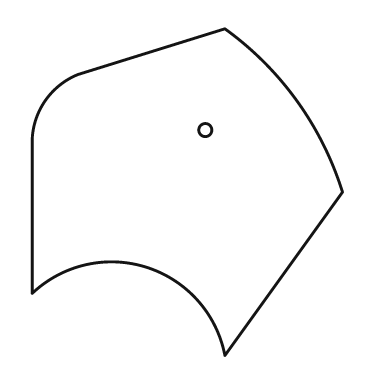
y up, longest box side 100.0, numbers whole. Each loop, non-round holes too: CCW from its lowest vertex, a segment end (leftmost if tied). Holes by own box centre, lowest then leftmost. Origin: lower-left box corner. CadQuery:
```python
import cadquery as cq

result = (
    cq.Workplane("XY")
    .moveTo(59.0, 0.0)
    .lineTo(95.0, 50.0)
    .threePointArc((81.0, 78.0), (59.0, 100.0))
    .lineTo(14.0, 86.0)
    .threePointArc((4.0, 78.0), (0.0, 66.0))
    .lineTo(0.0, 19.0)
    .threePointArc((35.0, 27.0), (59.0, 0.0))
    .close()
    .moveTo(53.0, 69.0)
    .circle(2.0)
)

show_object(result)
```